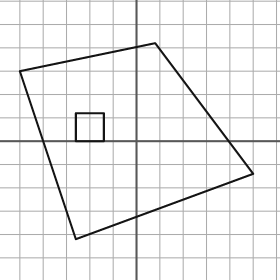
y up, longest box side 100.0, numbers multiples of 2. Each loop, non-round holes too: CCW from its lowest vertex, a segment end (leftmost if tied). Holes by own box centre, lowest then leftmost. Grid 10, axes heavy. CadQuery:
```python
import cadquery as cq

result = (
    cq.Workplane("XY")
    .moveTo(-26.0, -42.0)
    .lineTo(50.0, -14.0)
    .lineTo(8.0, 42.0)
    .lineTo(-50.0, 30.0)
    .close()
    .moveTo(-26.0, 0.0)
    .lineTo(-14.0, 0.0)
    .lineTo(-14.0, 12.0)
    .lineTo(-26.0, 12.0)
    .close()
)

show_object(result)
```